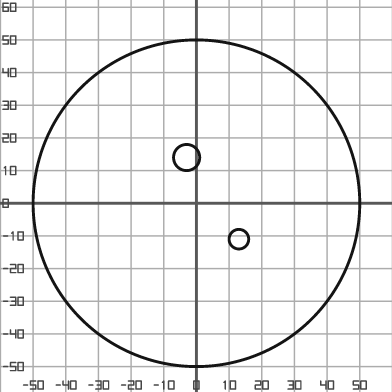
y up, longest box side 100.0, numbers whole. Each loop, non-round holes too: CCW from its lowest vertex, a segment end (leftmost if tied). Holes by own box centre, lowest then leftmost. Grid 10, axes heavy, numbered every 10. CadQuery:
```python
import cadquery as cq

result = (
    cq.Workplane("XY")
    .moveTo(0.0, 0.0)
    .circle(50.0)
    .moveTo(13.0, -11.0)
    .circle(3.0)
    .moveTo(-3.0, 14.0)
    .circle(4.0)
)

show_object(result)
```